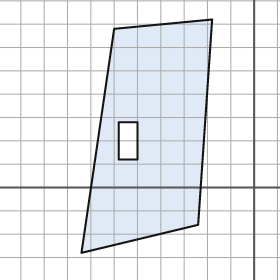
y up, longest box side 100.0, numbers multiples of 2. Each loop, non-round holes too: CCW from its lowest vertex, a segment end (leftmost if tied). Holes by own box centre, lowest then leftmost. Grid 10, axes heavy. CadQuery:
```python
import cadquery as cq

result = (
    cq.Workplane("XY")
    .moveTo(-74.0, -28.0)
    .lineTo(-24.0, -16.0)
    .lineTo(-18.0, 72.0)
    .lineTo(-60.0, 68.0)
    .close()
    .moveTo(-58.0, 12.0)
    .lineTo(-50.0, 12.0)
    .lineTo(-50.0, 28.0)
    .lineTo(-58.0, 28.0)
    .close()
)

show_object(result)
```